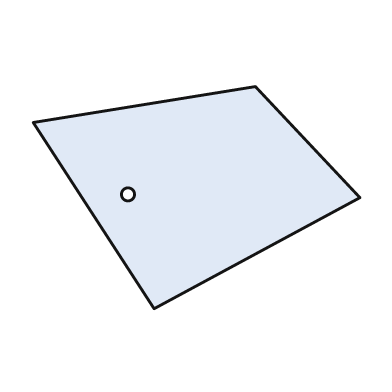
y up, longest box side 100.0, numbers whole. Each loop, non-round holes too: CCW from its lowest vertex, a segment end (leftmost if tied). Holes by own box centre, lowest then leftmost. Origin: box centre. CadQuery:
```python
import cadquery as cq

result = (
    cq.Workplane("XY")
    .moveTo(-13.0, -34.0)
    .lineTo(50.0, 0.0)
    .lineTo(18.0, 34.0)
    .lineTo(-50.0, 23.0)
    .close()
    .moveTo(-21.0, 1.0)
    .circle(2.0)
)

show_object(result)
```